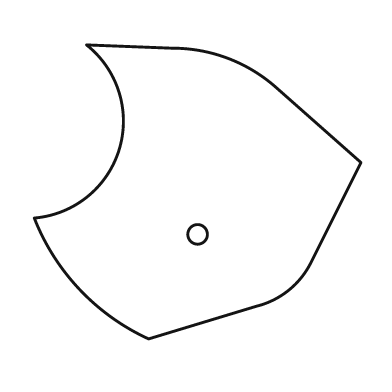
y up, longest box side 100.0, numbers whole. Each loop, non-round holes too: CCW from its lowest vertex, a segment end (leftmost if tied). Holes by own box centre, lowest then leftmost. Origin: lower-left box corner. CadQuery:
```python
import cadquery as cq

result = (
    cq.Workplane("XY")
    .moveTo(35.0, 0.0)
    .lineTo(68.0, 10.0)
    .threePointArc((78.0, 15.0), (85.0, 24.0))
    .lineTo(100.0, 54.0)
    .lineTo(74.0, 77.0)
    .threePointArc((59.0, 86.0), (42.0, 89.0))
    .lineTo(16.0, 90.0)
    .threePointArc((26.0, 58.0), (0.0, 37.0))
    .threePointArc((14.0, 15.0), (35.0, 0.0))
    .close()
    .moveTo(50.0, 32.0)
    .circle(3.0)
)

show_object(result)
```